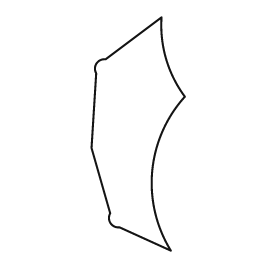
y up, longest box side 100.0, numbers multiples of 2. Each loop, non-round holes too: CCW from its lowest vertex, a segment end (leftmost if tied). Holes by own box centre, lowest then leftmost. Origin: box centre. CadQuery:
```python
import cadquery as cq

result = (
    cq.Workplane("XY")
    .moveTo(14.0, -50.0)
    .threePointArc((6.0, -16.0), (20.0, 16.0))
    .threePointArc((12.0, 32.0), (10.0, 50.0))
    .lineTo(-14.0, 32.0)
    .threePointArc((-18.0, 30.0), (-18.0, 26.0))
    .lineTo(-20.0, -6.0)
    .lineTo(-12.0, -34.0)
    .threePointArc((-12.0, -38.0), (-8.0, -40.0))
    .close()
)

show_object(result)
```